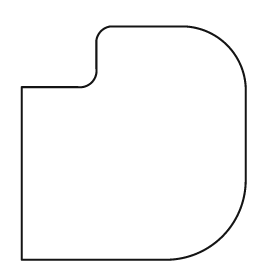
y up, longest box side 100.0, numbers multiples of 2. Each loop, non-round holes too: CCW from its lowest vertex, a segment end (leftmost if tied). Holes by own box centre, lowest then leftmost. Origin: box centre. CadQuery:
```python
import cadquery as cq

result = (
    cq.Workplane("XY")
    .moveTo(-48.0, -50.0)
    .lineTo(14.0, -50.0)
    .threePointArc((38.0, -40.0), (48.0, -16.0))
    .lineTo(48.0, 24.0)
    .threePointArc((40.0, 42.0), (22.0, 50.0))
    .lineTo(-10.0, 50.0)
    .threePointArc((-14.0, 48.0), (-16.0, 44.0))
    .lineTo(-16.0, 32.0)
    .threePointArc((-18.0, 26.0), (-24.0, 24.0))
    .lineTo(-48.0, 24.0)
    .close()
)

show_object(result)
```